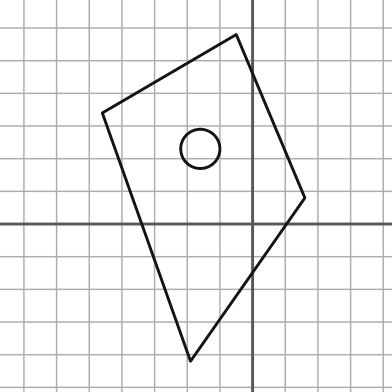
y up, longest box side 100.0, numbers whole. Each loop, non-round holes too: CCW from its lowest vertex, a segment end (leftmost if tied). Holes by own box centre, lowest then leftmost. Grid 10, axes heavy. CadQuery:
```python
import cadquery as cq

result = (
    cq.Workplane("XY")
    .moveTo(-19.0, -42.0)
    .lineTo(16.0, 8.0)
    .lineTo(-5.0, 58.0)
    .lineTo(-46.0, 34.0)
    .close()
    .moveTo(-16.0, 23.0)
    .circle(6.0)
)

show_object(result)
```